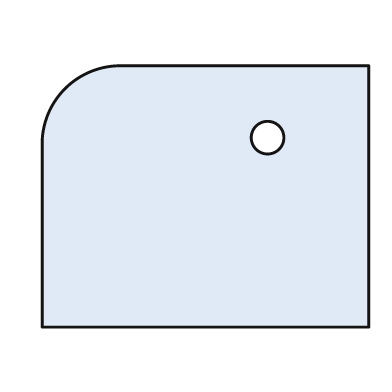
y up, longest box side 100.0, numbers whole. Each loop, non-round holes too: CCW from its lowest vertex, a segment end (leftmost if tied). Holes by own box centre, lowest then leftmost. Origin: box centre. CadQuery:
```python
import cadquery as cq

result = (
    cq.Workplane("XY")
    .moveTo(-50.0, -40.0)
    .lineTo(50.0, -40.0)
    .lineTo(50.0, 40.0)
    .lineTo(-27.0, 40.0)
    .threePointArc((-43.0, 33.0), (-50.0, 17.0))
    .close()
    .moveTo(19.0, 18.0)
    .circle(5.0)
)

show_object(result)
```